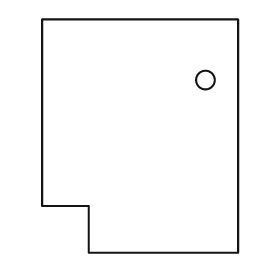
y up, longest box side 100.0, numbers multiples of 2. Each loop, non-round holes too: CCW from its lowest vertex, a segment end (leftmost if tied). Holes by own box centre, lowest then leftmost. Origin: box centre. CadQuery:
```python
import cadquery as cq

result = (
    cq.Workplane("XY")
    .moveTo(-22.0, -50.0)
    .lineTo(42.0, -50.0)
    .lineTo(42.0, 50.0)
    .lineTo(-42.0, 50.0)
    .lineTo(-42.0, -30.0)
    .lineTo(-22.0, -30.0)
    .close()
    .moveTo(28.0, 24.0)
    .circle(4.0)
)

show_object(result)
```